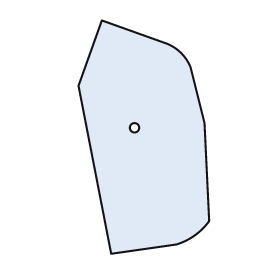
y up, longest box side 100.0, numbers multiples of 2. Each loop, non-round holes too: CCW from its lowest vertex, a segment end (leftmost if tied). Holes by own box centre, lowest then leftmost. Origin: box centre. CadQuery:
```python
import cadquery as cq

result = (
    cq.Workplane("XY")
    .moveTo(-14.0, -50.0)
    .lineTo(14.0, -46.0)
    .threePointArc((22.0, -42.0), (28.0, -36.0))
    .lineTo(26.0, 6.0)
    .lineTo(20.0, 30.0)
    .threePointArc((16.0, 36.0), (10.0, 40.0))
    .lineTo(-18.0, 50.0)
    .lineTo(-28.0, 22.0)
    .close()
    .moveTo(-4.0, 4.0)
    .circle(2.0)
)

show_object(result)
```